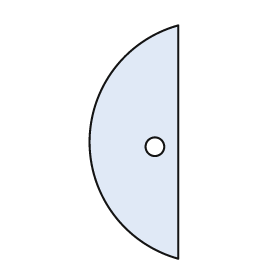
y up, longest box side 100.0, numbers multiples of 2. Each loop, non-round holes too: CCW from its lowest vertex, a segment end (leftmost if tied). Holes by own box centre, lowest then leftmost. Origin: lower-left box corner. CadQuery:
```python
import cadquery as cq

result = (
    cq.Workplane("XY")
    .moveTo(38.0, 0.0)
    .lineTo(38.0, 100.0)
    .threePointArc((0.0, 50.0), (38.0, 0.0))
    .close()
    .moveTo(28.0, 48.0)
    .circle(4.0)
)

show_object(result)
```